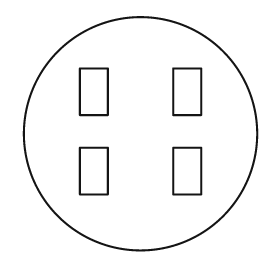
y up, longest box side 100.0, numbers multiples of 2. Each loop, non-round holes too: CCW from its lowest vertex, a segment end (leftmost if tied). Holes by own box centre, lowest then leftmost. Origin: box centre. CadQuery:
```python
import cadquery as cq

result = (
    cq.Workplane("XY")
    .moveTo(0.0, 0.0)
    .circle(50.0)
    .moveTo(-26.0, -26.0)
    .lineTo(-14.0, -26.0)
    .lineTo(-14.0, -6.0)
    .lineTo(-26.0, -6.0)
    .close()
    .moveTo(14.0, -26.0)
    .lineTo(26.0, -26.0)
    .lineTo(26.0, -6.0)
    .lineTo(14.0, -6.0)
    .close()
    .moveTo(-26.0, 8.0)
    .lineTo(-14.0, 8.0)
    .lineTo(-14.0, 28.0)
    .lineTo(-26.0, 28.0)
    .close()
    .moveTo(14.0, 8.0)
    .lineTo(26.0, 8.0)
    .lineTo(26.0, 28.0)
    .lineTo(14.0, 28.0)
    .close()
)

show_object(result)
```